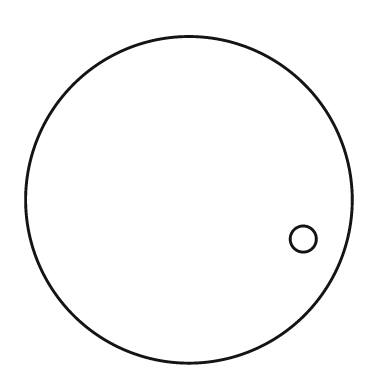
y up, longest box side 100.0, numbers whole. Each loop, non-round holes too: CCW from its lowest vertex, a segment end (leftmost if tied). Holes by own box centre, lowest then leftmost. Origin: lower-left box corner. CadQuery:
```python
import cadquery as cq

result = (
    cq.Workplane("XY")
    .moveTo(50.0, 50.0)
    .circle(50.0)
    .moveTo(85.0, 38.0)
    .circle(4.0)
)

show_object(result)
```